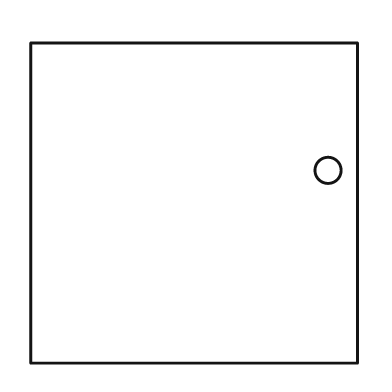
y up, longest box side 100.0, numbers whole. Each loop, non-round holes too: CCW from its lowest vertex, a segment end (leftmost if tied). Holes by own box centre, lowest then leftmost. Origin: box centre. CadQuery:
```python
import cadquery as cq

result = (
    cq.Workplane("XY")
    .moveTo(-50.0, -49.0)
    .lineTo(50.0, -49.0)
    .lineTo(50.0, 49.0)
    .lineTo(-50.0, 49.0)
    .close()
    .moveTo(41.0, 10.0)
    .circle(4.0)
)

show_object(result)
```